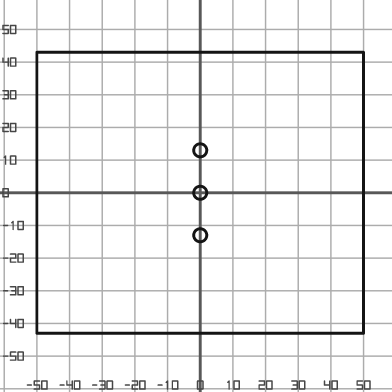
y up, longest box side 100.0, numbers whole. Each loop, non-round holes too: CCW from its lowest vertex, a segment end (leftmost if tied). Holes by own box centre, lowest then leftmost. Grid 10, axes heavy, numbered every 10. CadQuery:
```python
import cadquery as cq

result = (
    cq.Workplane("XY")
    .moveTo(-50.0, -43.0)
    .lineTo(50.0, -43.0)
    .lineTo(50.0, 43.0)
    .lineTo(-50.0, 43.0)
    .close()
    .moveTo(0.0, -13.0)
    .circle(2.0)
    .moveTo(0.0, 0.0)
    .circle(2.0)
    .moveTo(0.0, 13.0)
    .circle(2.0)
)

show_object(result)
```